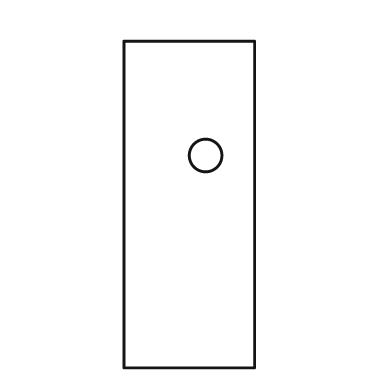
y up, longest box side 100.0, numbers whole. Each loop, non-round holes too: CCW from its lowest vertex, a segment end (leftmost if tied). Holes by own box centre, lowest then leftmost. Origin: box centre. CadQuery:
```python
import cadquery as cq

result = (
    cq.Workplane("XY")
    .moveTo(-20.0, -50.0)
    .lineTo(20.0, -50.0)
    .lineTo(20.0, 50.0)
    .lineTo(-20.0, 50.0)
    .close()
    .moveTo(5.0, 15.0)
    .circle(5.0)
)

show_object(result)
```